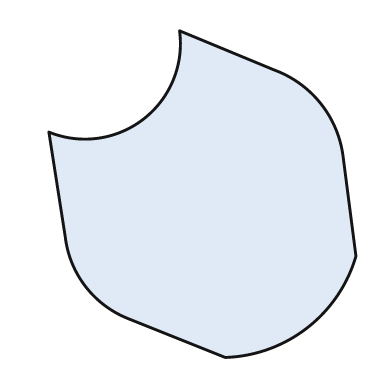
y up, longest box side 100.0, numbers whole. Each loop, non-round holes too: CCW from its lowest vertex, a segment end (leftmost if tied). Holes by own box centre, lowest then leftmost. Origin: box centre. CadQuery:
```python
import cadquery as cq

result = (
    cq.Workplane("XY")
    .moveTo(7.0, -50.0)
    .threePointArc((32.0, -41.0), (47.0, -19.0))
    .lineTo(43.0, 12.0)
    .threePointArc((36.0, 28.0), (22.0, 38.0))
    .lineTo(-7.0, 50.0)
    .threePointArc((-18.0, 23.0), (-47.0, 19.0))
    .lineTo(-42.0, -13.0)
    .threePointArc((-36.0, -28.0), (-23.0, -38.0))
    .close()
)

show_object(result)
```